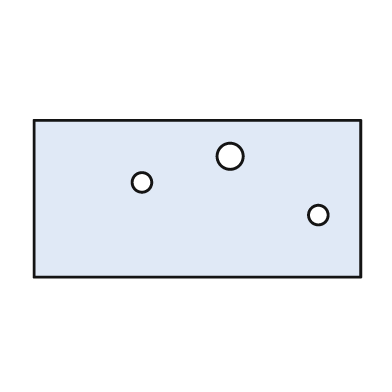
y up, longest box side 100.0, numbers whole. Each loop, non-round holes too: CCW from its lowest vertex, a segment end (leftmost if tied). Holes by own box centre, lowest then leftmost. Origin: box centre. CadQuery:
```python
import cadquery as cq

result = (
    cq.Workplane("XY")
    .moveTo(-50.0, -24.0)
    .lineTo(50.0, -24.0)
    .lineTo(50.0, 24.0)
    .lineTo(-50.0, 24.0)
    .close()
    .moveTo(37.0, -5.0)
    .circle(3.0)
    .moveTo(-17.0, 5.0)
    .circle(3.0)
    .moveTo(10.0, 13.0)
    .circle(4.0)
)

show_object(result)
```